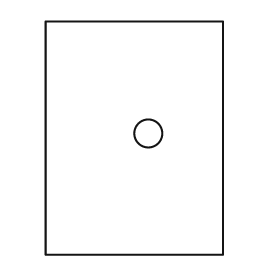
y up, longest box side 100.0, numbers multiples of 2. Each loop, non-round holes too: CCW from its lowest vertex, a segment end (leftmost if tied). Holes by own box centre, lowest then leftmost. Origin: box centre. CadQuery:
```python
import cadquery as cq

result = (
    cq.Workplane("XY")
    .moveTo(-38.0, -50.0)
    .lineTo(38.0, -50.0)
    .lineTo(38.0, 50.0)
    .lineTo(-38.0, 50.0)
    .close()
    .moveTo(6.0, 2.0)
    .circle(6.0)
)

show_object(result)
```